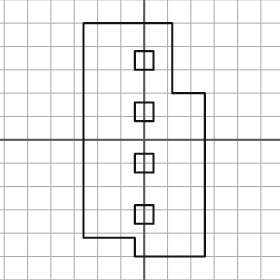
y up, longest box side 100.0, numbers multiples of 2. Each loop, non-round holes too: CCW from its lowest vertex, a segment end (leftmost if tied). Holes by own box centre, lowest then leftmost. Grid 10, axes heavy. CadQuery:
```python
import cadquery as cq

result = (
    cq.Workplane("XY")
    .moveTo(-4.0, -50.0)
    .lineTo(26.0, -50.0)
    .lineTo(26.0, 20.0)
    .lineTo(12.0, 20.0)
    .lineTo(12.0, 50.0)
    .lineTo(-26.0, 50.0)
    .lineTo(-26.0, -42.0)
    .lineTo(-4.0, -42.0)
    .close()
    .moveTo(-4.0, -36.0)
    .lineTo(4.0, -36.0)
    .lineTo(4.0, -28.0)
    .lineTo(-4.0, -28.0)
    .close()
    .moveTo(-4.0, -14.0)
    .lineTo(4.0, -14.0)
    .lineTo(4.0, -6.0)
    .lineTo(-4.0, -6.0)
    .close()
    .moveTo(-4.0, 8.0)
    .lineTo(4.0, 8.0)
    .lineTo(4.0, 16.0)
    .lineTo(-4.0, 16.0)
    .close()
    .moveTo(-4.0, 30.0)
    .lineTo(4.0, 30.0)
    .lineTo(4.0, 38.0)
    .lineTo(-4.0, 38.0)
    .close()
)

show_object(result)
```